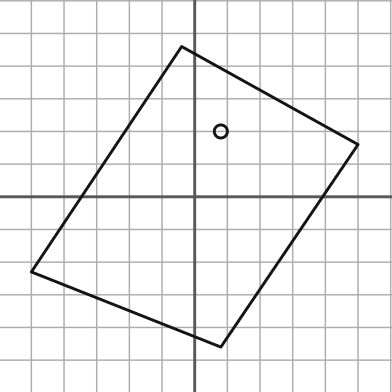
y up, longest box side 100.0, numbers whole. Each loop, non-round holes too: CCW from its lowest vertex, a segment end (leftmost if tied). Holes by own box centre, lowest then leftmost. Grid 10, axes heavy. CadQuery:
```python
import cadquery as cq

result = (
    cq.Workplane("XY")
    .moveTo(8.0, -46.0)
    .lineTo(50.0, 16.0)
    .lineTo(-4.0, 46.0)
    .lineTo(-50.0, -23.0)
    .close()
    .moveTo(8.0, 20.0)
    .circle(2.0)
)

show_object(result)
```